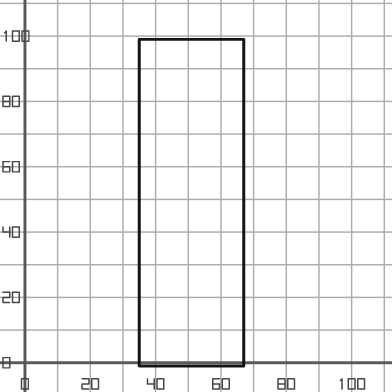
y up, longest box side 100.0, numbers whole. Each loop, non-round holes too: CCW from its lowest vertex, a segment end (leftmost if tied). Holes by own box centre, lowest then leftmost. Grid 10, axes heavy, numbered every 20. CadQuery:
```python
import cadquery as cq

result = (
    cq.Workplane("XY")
    .moveTo(35.0, -1.0)
    .lineTo(67.0, -1.0)
    .lineTo(67.0, 99.0)
    .lineTo(35.0, 99.0)
    .close()
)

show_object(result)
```